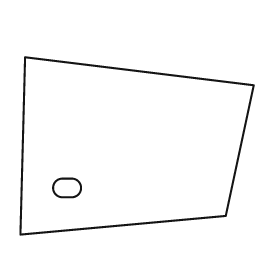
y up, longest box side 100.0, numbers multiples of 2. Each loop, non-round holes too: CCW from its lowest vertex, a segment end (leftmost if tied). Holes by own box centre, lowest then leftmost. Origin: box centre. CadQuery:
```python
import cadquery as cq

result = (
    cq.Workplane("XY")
    .moveTo(-50.0, -38.0)
    .lineTo(38.0, -30.0)
    .lineTo(50.0, 26.0)
    .lineTo(-48.0, 38.0)
    .close()
    .moveTo(-32.0, -22.0)
    .lineTo(-28.0, -22.0)
    .threePointArc((-24.0, -18.0), (-28.0, -14.0))
    .lineTo(-32.0, -14.0)
    .threePointArc((-36.0, -18.0), (-32.0, -22.0))
    .close()
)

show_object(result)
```